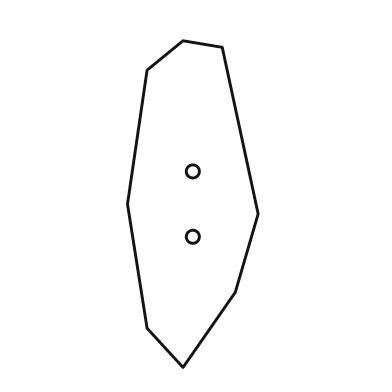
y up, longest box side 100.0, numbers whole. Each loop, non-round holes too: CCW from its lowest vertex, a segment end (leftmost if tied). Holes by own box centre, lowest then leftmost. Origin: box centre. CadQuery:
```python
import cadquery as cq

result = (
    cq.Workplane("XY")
    .moveTo(-3.0, -50.0)
    .lineTo(13.0, -27.0)
    .lineTo(20.0, -3.0)
    .lineTo(9.0, 48.0)
    .lineTo(-3.0, 50.0)
    .lineTo(-14.0, 41.0)
    .lineTo(-20.0, 0.0)
    .lineTo(-14.0, -38.0)
    .close()
    .moveTo(0.0, -10.0)
    .circle(2.0)
    .moveTo(0.0, 10.0)
    .circle(2.0)
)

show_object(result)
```